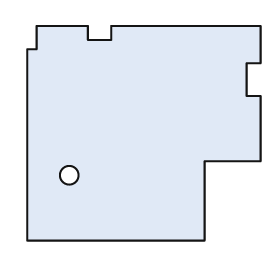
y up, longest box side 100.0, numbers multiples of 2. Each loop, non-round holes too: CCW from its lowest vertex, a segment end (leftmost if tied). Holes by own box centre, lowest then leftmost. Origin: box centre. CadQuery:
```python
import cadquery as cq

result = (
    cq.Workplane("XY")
    .moveTo(-50.0, -46.0)
    .lineTo(26.0, -46.0)
    .lineTo(26.0, -12.0)
    .lineTo(50.0, -12.0)
    .lineTo(50.0, 16.0)
    .lineTo(44.0, 16.0)
    .lineTo(44.0, 30.0)
    .lineTo(50.0, 30.0)
    .lineTo(50.0, 46.0)
    .lineTo(-14.0, 46.0)
    .lineTo(-14.0, 40.0)
    .lineTo(-24.0, 40.0)
    .lineTo(-24.0, 46.0)
    .lineTo(-46.0, 46.0)
    .lineTo(-46.0, 36.0)
    .lineTo(-50.0, 36.0)
    .close()
    .moveTo(-32.0, -18.0)
    .circle(4.0)
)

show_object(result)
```